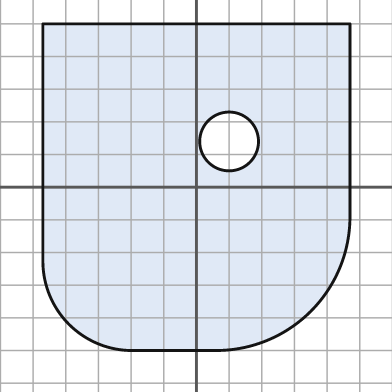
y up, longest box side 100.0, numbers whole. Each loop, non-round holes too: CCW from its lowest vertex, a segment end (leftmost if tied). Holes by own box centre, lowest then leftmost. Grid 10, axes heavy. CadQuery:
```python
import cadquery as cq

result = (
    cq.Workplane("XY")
    .moveTo(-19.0, -50.0)
    .lineTo(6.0, -50.0)
    .threePointArc((35.0, -38.0), (47.0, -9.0))
    .lineTo(47.0, 50.0)
    .lineTo(-47.0, 50.0)
    .lineTo(-47.0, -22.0)
    .threePointArc((-39.0, -42.0), (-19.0, -50.0))
    .close()
    .moveTo(10.0, 14.0)
    .circle(9.0)
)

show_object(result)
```